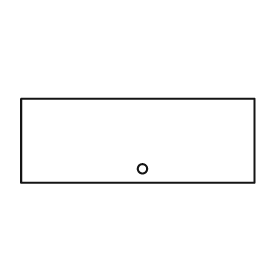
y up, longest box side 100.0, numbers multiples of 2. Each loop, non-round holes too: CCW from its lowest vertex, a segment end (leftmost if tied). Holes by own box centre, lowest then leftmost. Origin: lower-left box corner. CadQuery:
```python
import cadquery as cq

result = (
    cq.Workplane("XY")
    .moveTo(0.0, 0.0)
    .lineTo(100.0, 0.0)
    .lineTo(100.0, 36.0)
    .lineTo(0.0, 36.0)
    .close()
    .moveTo(52.0, 6.0)
    .circle(2.0)
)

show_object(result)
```